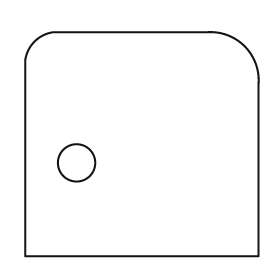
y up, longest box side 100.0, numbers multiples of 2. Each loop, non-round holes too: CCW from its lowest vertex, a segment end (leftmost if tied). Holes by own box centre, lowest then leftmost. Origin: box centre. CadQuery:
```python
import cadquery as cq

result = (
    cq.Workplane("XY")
    .moveTo(-50.0, -48.0)
    .lineTo(50.0, -48.0)
    .lineTo(50.0, 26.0)
    .threePointArc((44.0, 42.0), (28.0, 48.0))
    .lineTo(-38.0, 48.0)
    .threePointArc((-46.0, 44.0), (-50.0, 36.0))
    .close()
    .moveTo(-28.0, -8.0)
    .circle(8.0)
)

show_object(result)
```